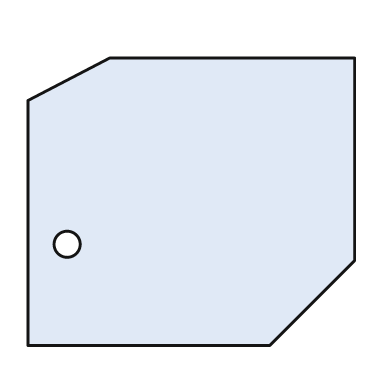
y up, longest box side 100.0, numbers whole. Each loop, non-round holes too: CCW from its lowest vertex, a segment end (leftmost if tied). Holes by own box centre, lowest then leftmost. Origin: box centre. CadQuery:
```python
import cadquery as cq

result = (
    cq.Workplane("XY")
    .moveTo(-50.0, -44.0)
    .lineTo(24.0, -44.0)
    .lineTo(50.0, -18.0)
    .lineTo(50.0, 44.0)
    .lineTo(-25.0, 44.0)
    .lineTo(-50.0, 31.0)
    .close()
    .moveTo(-38.0, -13.0)
    .circle(4.0)
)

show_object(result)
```